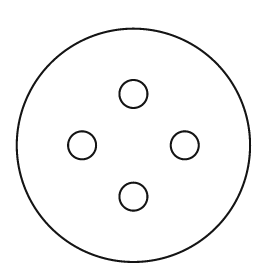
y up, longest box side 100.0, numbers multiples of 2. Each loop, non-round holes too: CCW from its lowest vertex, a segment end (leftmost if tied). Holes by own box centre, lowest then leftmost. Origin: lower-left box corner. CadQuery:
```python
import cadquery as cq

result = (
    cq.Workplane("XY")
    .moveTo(50.0, 50.0)
    .circle(50.0)
    .moveTo(50.0, 28.0)
    .circle(6.0)
    .moveTo(28.0, 50.0)
    .circle(6.0)
    .moveTo(72.0, 50.0)
    .circle(6.0)
    .moveTo(50.0, 72.0)
    .circle(6.0)
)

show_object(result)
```